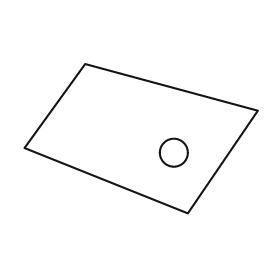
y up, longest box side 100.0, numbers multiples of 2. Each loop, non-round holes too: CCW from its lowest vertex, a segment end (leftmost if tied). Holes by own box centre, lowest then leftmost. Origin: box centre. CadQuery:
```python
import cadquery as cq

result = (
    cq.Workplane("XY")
    .moveTo(20.0, -32.0)
    .lineTo(50.0, 12.0)
    .lineTo(-24.0, 32.0)
    .lineTo(-50.0, -4.0)
    .close()
    .moveTo(14.0, -6.0)
    .circle(6.0)
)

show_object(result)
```